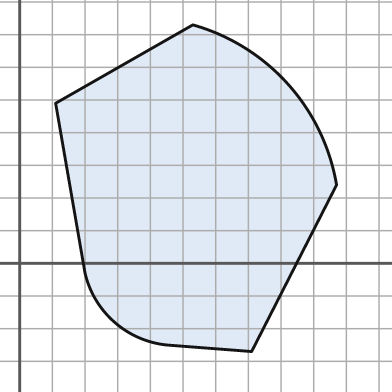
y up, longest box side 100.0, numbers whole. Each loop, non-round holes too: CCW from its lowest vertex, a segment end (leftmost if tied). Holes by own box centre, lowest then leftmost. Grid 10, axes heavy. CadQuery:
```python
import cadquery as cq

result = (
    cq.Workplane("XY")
    .moveTo(71.0, -27.0)
    .lineTo(97.0, 24.0)
    .threePointArc((82.0, 55.0), (53.0, 73.0))
    .lineTo(11.0, 49.0)
    .lineTo(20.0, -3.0)
    .threePointArc((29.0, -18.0), (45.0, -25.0))
    .close()
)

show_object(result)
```